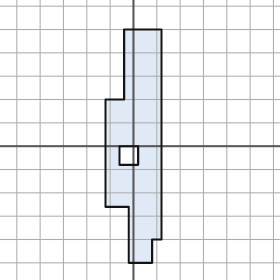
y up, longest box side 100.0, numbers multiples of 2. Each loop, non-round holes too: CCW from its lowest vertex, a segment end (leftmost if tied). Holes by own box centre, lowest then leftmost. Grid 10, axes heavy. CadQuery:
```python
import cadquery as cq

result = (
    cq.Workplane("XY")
    .moveTo(-2.0, -50.0)
    .lineTo(8.0, -50.0)
    .lineTo(8.0, -40.0)
    .lineTo(12.0, -40.0)
    .lineTo(12.0, 50.0)
    .lineTo(-4.0, 50.0)
    .lineTo(-4.0, 20.0)
    .lineTo(-12.0, 20.0)
    .lineTo(-12.0, -26.0)
    .lineTo(-2.0, -26.0)
    .close()
    .moveTo(-6.0, -8.0)
    .lineTo(2.0, -8.0)
    .lineTo(2.0, 0.0)
    .lineTo(-6.0, 0.0)
    .close()
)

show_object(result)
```